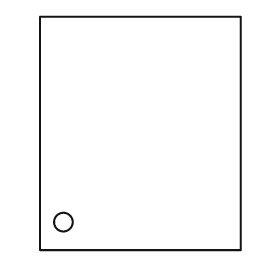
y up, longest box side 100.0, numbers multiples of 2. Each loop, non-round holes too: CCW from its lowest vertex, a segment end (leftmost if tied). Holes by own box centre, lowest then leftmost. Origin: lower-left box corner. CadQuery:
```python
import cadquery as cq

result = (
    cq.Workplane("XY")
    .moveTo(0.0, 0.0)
    .lineTo(86.0, 0.0)
    .lineTo(86.0, 100.0)
    .lineTo(0.0, 100.0)
    .close()
    .moveTo(10.0, 12.0)
    .circle(4.0)
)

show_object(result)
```